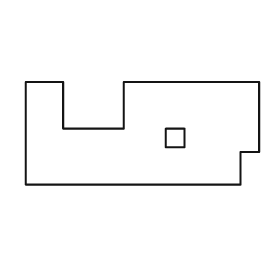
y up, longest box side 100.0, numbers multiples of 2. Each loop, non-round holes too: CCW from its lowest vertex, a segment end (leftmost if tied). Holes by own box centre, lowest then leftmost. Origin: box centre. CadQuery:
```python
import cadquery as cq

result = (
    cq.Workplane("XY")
    .moveTo(-50.0, -22.0)
    .lineTo(42.0, -22.0)
    .lineTo(42.0, -8.0)
    .lineTo(50.0, -8.0)
    .lineTo(50.0, 22.0)
    .lineTo(-8.0, 22.0)
    .lineTo(-8.0, 2.0)
    .lineTo(-34.0, 2.0)
    .lineTo(-34.0, 22.0)
    .lineTo(-50.0, 22.0)
    .close()
    .moveTo(10.0, -6.0)
    .lineTo(18.0, -6.0)
    .lineTo(18.0, 2.0)
    .lineTo(10.0, 2.0)
    .close()
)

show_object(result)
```